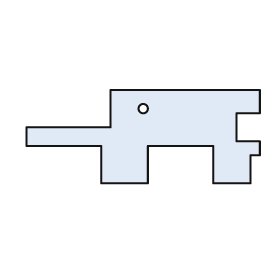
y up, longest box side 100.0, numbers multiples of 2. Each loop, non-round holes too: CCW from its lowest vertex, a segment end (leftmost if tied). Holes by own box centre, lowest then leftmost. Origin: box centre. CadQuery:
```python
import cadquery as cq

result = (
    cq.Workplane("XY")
    .moveTo(-18.0, -20.0)
    .lineTo(2.0, -20.0)
    .lineTo(2.0, -4.0)
    .lineTo(30.0, -4.0)
    .lineTo(30.0, -20.0)
    .lineTo(46.0, -20.0)
    .lineTo(46.0, -8.0)
    .lineTo(50.0, -8.0)
    .lineTo(50.0, -2.0)
    .lineTo(40.0, -2.0)
    .lineTo(40.0, 10.0)
    .lineTo(50.0, 10.0)
    .lineTo(50.0, 20.0)
    .lineTo(-14.0, 20.0)
    .lineTo(-14.0, 4.0)
    .lineTo(-50.0, 4.0)
    .lineTo(-50.0, -4.0)
    .lineTo(-18.0, -4.0)
    .close()
    .moveTo(0.0, 12.0)
    .circle(2.0)
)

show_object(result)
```